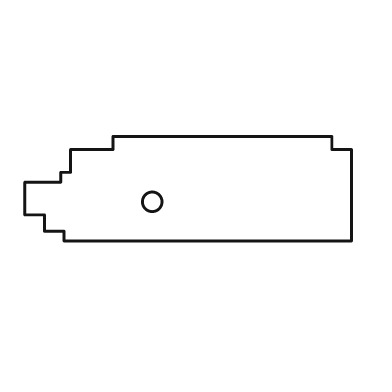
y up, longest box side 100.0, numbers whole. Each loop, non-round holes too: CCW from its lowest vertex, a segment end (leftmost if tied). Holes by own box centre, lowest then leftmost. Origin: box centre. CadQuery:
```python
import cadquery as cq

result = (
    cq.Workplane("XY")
    .moveTo(-38.0, -16.0)
    .lineTo(50.0, -16.0)
    .lineTo(50.0, 12.0)
    .lineTo(44.0, 12.0)
    .lineTo(44.0, 16.0)
    .lineTo(-23.0, 16.0)
    .lineTo(-23.0, 12.0)
    .lineTo(-36.0, 12.0)
    .lineTo(-36.0, 5.0)
    .lineTo(-39.0, 5.0)
    .lineTo(-39.0, 2.0)
    .lineTo(-50.0, 2.0)
    .lineTo(-50.0, -8.0)
    .lineTo(-44.0, -8.0)
    .lineTo(-44.0, -13.0)
    .lineTo(-38.0, -13.0)
    .close()
    .moveTo(-11.0, -4.0)
    .circle(3.0)
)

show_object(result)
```